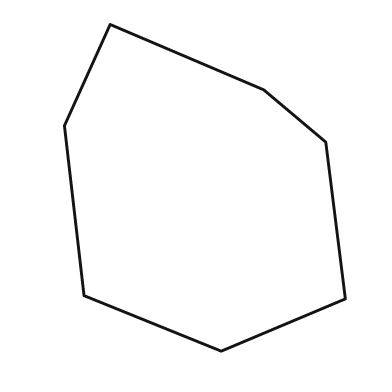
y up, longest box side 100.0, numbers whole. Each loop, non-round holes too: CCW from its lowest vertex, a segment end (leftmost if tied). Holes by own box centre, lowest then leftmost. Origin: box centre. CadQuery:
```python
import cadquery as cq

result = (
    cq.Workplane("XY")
    .moveTo(5.0, -50.0)
    .lineTo(43.0, -34.0)
    .lineTo(37.0, 14.0)
    .lineTo(18.0, 30.0)
    .lineTo(-29.0, 50.0)
    .lineTo(-43.0, 19.0)
    .lineTo(-37.0, -33.0)
    .close()
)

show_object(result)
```